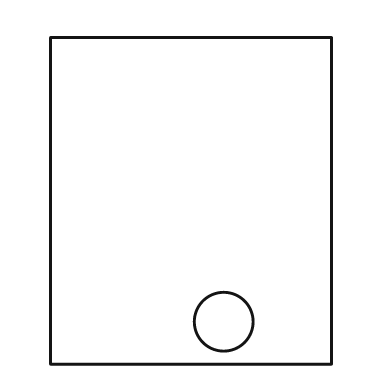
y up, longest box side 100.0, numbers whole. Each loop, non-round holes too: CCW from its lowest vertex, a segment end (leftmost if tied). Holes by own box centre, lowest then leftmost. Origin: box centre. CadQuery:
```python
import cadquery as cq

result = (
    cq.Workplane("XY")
    .moveTo(-43.0, -50.0)
    .lineTo(43.0, -50.0)
    .lineTo(43.0, 50.0)
    .lineTo(-43.0, 50.0)
    .close()
    .moveTo(10.0, -37.0)
    .circle(9.0)
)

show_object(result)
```